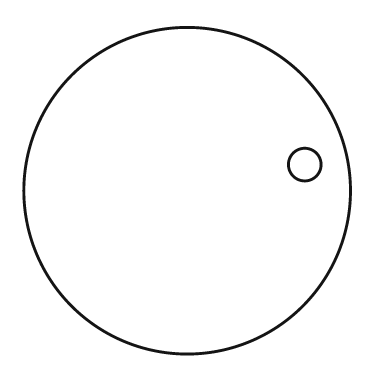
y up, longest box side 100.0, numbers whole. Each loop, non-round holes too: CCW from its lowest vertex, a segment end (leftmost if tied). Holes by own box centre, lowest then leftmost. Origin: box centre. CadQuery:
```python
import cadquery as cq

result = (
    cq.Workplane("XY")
    .moveTo(0.0, 0.0)
    .circle(50.0)
    .moveTo(36.0, 8.0)
    .circle(5.0)
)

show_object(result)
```